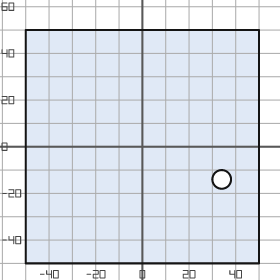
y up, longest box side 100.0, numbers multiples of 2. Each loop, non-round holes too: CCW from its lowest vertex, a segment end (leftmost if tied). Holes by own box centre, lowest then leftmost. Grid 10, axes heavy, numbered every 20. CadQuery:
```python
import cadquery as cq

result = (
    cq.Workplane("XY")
    .moveTo(-50.0, -50.0)
    .lineTo(50.0, -50.0)
    .lineTo(50.0, 50.0)
    .lineTo(-50.0, 50.0)
    .close()
    .moveTo(34.0, -14.0)
    .circle(4.0)
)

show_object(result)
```